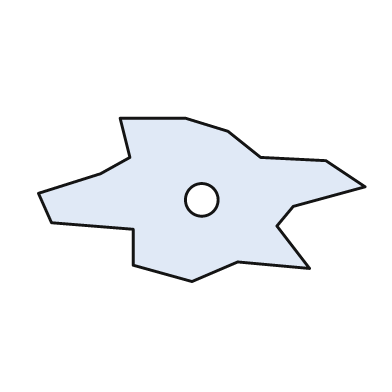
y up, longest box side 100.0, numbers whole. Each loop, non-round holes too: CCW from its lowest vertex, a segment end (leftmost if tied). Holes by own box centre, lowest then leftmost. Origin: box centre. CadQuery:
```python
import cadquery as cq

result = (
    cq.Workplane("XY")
    .moveTo(-3.0, -25.0)
    .lineTo(11.0, -19.0)
    .lineTo(33.0, -21.0)
    .lineTo(23.0, -8.0)
    .lineTo(28.0, -2.0)
    .lineTo(50.0, 4.0)
    .lineTo(38.0, 12.0)
    .lineTo(18.0, 13.0)
    .lineTo(8.0, 21.0)
    .lineTo(-5.0, 25.0)
    .lineTo(-25.0, 25.0)
    .lineTo(-22.0, 13.0)
    .lineTo(-31.0, 8.0)
    .lineTo(-50.0, 2.0)
    .lineTo(-46.0, -7.0)
    .lineTo(-21.0, -9.0)
    .lineTo(-21.0, -20.0)
    .close()
    .moveTo(0.0, 0.0)
    .circle(5.0)
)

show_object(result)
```